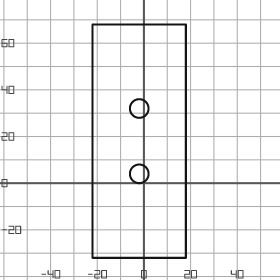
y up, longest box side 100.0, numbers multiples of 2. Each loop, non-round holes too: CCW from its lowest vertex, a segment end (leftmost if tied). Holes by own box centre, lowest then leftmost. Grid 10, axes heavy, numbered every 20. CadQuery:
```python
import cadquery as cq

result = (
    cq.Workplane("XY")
    .moveTo(-22.0, -32.0)
    .lineTo(18.0, -32.0)
    .lineTo(18.0, 68.0)
    .lineTo(-22.0, 68.0)
    .close()
    .moveTo(-2.0, 4.0)
    .circle(4.0)
    .moveTo(-2.0, 32.0)
    .circle(4.0)
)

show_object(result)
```